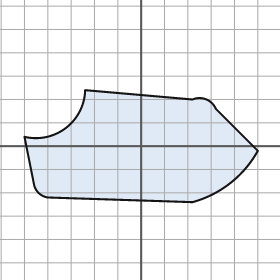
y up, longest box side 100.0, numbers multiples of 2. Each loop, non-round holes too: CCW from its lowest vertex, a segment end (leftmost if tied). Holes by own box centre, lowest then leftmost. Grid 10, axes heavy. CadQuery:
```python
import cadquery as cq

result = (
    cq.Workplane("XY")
    .moveTo(22.0, -24.0)
    .threePointArc((38.0, -16.0), (50.0, -2.0))
    .lineTo(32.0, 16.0)
    .threePointArc((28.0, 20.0), (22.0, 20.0))
    .lineTo(-24.0, 24.0)
    .threePointArc((-32.0, 8.0), (-50.0, 4.0))
    .lineTo(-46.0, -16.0)
    .threePointArc((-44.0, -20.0), (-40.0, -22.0))
    .close()
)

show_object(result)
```